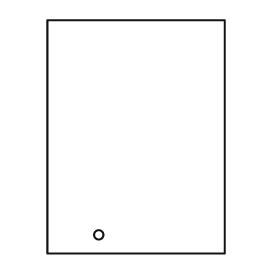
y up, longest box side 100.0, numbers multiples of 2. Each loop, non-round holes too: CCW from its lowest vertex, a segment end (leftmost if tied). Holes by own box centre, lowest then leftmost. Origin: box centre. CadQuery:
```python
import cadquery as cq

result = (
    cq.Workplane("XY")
    .moveTo(-38.0, -50.0)
    .lineTo(38.0, -50.0)
    .lineTo(38.0, 50.0)
    .lineTo(-38.0, 50.0)
    .close()
    .moveTo(-16.0, -42.0)
    .circle(2.0)
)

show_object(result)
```